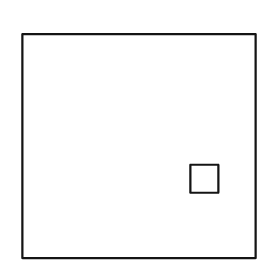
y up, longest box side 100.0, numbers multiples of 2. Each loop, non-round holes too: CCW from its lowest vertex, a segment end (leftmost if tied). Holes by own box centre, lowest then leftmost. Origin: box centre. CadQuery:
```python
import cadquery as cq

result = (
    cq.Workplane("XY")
    .moveTo(-50.0, -48.0)
    .lineTo(50.0, -48.0)
    .lineTo(50.0, 48.0)
    .lineTo(-50.0, 48.0)
    .close()
    .moveTo(22.0, -20.0)
    .lineTo(34.0, -20.0)
    .lineTo(34.0, -8.0)
    .lineTo(22.0, -8.0)
    .close()
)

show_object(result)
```